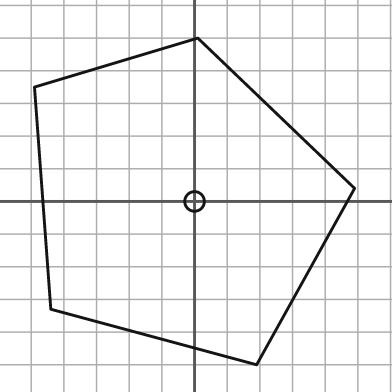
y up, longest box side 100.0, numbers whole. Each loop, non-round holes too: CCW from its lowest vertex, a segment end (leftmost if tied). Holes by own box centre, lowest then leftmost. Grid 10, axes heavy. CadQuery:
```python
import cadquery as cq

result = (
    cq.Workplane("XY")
    .moveTo(19.0, -50.0)
    .lineTo(49.0, 4.0)
    .lineTo(1.0, 50.0)
    .lineTo(-49.0, 35.0)
    .lineTo(-44.0, -33.0)
    .close()
    .moveTo(0.0, 0.0)
    .circle(3.0)
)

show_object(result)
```